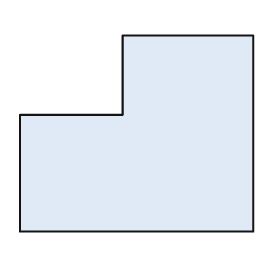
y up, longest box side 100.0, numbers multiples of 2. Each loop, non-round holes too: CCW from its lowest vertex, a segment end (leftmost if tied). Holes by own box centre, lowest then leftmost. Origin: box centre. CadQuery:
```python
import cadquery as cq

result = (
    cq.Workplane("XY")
    .moveTo(-50.0, -42.0)
    .lineTo(50.0, -42.0)
    .lineTo(50.0, 42.0)
    .lineTo(-6.0, 42.0)
    .lineTo(-6.0, 8.0)
    .lineTo(-50.0, 8.0)
    .close()
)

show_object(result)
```